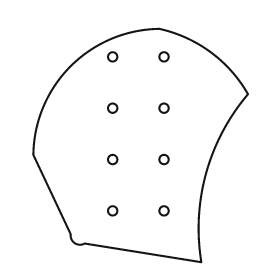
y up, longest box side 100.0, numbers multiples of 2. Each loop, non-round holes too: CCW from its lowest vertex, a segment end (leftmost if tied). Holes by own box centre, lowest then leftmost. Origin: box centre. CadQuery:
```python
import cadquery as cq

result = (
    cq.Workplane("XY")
    .moveTo(26.0, -50.0)
    .threePointArc((28.0, -12.0), (46.0, 22.0))
    .threePointArc((30.0, 40.0), (8.0, 50.0))
    .threePointArc((-30.0, 34.0), (-46.0, -4.0))
    .lineTo(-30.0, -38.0)
    .threePointArc((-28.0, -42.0), (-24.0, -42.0))
    .close()
    .moveTo(-12.0, -28.0)
    .circle(2.0)
    .moveTo(10.0, -28.0)
    .circle(2.0)
    .moveTo(-12.0, -6.0)
    .circle(2.0)
    .moveTo(10.0, -6.0)
    .circle(2.0)
    .moveTo(-12.0, 16.0)
    .circle(2.0)
    .moveTo(10.0, 16.0)
    .circle(2.0)
    .moveTo(-12.0, 38.0)
    .circle(2.0)
    .moveTo(10.0, 38.0)
    .circle(2.0)
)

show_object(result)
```